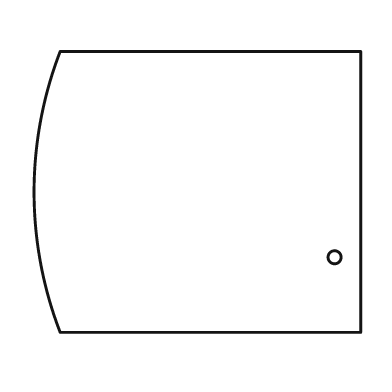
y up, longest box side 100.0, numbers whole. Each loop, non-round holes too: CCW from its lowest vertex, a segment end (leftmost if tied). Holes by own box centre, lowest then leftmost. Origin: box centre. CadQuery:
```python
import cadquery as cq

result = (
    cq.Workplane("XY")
    .moveTo(-42.0, -43.0)
    .lineTo(50.0, -43.0)
    .lineTo(50.0, 43.0)
    .lineTo(-42.0, 43.0)
    .threePointArc((-50.0, 0.0), (-42.0, -43.0))
    .close()
    .moveTo(42.0, -20.0)
    .circle(2.0)
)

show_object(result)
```